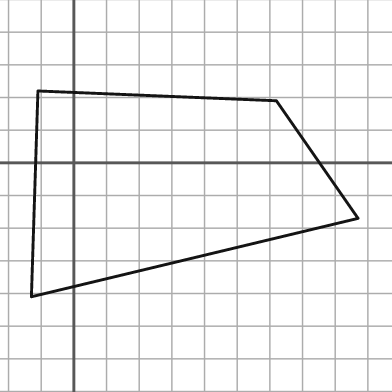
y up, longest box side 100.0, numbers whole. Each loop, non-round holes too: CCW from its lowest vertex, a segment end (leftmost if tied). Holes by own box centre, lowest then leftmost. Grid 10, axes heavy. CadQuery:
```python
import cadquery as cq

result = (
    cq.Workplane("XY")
    .moveTo(-13.0, -41.0)
    .lineTo(87.0, -17.0)
    .lineTo(62.0, 19.0)
    .lineTo(-11.0, 22.0)
    .close()
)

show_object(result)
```